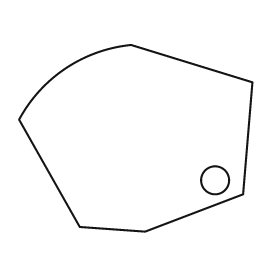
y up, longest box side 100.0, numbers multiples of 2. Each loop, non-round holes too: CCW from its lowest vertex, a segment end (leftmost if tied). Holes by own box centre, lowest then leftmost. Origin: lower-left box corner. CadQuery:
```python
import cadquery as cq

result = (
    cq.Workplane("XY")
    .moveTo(54.0, 0.0)
    .lineTo(96.0, 16.0)
    .lineTo(100.0, 64.0)
    .lineTo(48.0, 80.0)
    .threePointArc((20.0, 70.0), (0.0, 48.0))
    .lineTo(26.0, 2.0)
    .close()
    .moveTo(84.0, 22.0)
    .circle(6.0)
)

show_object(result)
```